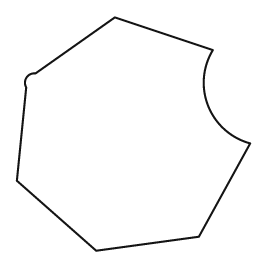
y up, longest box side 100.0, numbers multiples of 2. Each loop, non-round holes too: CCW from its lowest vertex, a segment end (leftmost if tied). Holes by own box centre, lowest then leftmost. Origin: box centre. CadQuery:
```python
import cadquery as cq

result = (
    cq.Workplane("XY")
    .moveTo(-16.0, -50.0)
    .lineTo(28.0, -44.0)
    .lineTo(50.0, -4.0)
    .threePointArc((32.0, 12.0), (34.0, 36.0))
    .lineTo(-8.0, 50.0)
    .lineTo(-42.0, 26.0)
    .threePointArc((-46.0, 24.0), (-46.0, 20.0))
    .lineTo(-50.0, -20.0)
    .close()
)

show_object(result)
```